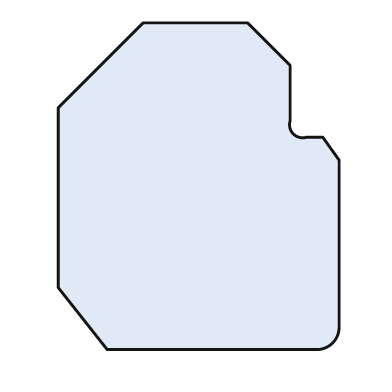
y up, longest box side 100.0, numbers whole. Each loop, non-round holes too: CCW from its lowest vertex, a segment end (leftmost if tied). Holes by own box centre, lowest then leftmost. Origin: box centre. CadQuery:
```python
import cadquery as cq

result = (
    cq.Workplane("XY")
    .moveTo(-28.0, -50.0)
    .lineTo(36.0, -50.0)
    .threePointArc((41.0, -48.0), (43.0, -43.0))
    .lineTo(43.0, 8.0)
    .lineTo(38.0, 15.0)
    .lineTo(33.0, 15.0)
    .threePointArc((29.0, 16.0), (28.0, 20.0))
    .lineTo(28.0, 37.0)
    .lineTo(15.0, 50.0)
    .lineTo(-17.0, 50.0)
    .lineTo(-43.0, 24.0)
    .lineTo(-43.0, -31.0)
    .close()
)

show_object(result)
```